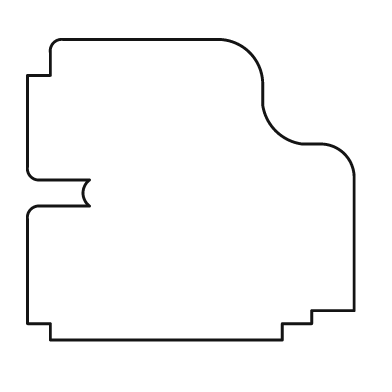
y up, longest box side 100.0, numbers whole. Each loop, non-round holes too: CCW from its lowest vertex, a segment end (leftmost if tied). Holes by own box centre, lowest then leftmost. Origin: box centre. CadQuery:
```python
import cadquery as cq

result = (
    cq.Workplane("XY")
    .moveTo(-43.0, -46.0)
    .lineTo(28.0, -46.0)
    .lineTo(28.0, -41.0)
    .lineTo(37.0, -41.0)
    .lineTo(37.0, -37.0)
    .lineTo(50.0, -37.0)
    .lineTo(50.0, 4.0)
    .threePointArc((47.0, 11.0), (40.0, 14.0))
    .lineTo(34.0, 14.0)
    .threePointArc((26.0, 18.0), (22.0, 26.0))
    .lineTo(22.0, 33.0)
    .threePointArc((18.0, 42.0), (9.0, 46.0))
    .lineTo(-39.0, 46.0)
    .threePointArc((-42.0, 45.0), (-43.0, 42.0))
    .lineTo(-43.0, 35.0)
    .lineTo(-50.0, 35.0)
    .lineTo(-50.0, 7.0)
    .threePointArc((-49.0, 4.0), (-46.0, 3.0))
    .lineTo(-31.0, 3.0)
    .threePointArc((-33.0, -1.0), (-31.0, -5.0))
    .lineTo(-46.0, -5.0)
    .threePointArc((-49.0, -6.0), (-50.0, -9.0))
    .lineTo(-50.0, -41.0)
    .lineTo(-43.0, -41.0)
    .close()
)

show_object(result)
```